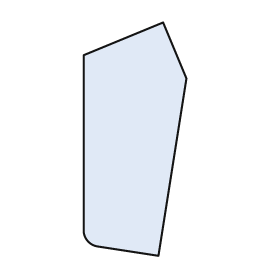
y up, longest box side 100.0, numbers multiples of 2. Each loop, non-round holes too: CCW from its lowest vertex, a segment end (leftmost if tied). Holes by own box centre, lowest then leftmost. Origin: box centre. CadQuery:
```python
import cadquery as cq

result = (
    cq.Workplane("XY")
    .moveTo(10.0, -50.0)
    .lineTo(22.0, 26.0)
    .lineTo(12.0, 50.0)
    .lineTo(-22.0, 36.0)
    .lineTo(-22.0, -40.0)
    .threePointArc((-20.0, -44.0), (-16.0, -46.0))
    .close()
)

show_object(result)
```